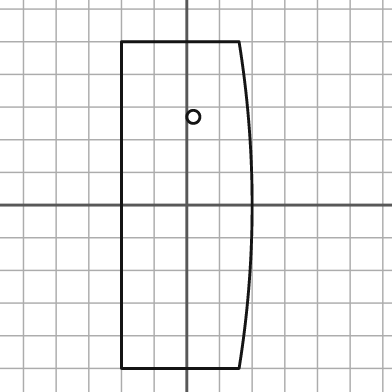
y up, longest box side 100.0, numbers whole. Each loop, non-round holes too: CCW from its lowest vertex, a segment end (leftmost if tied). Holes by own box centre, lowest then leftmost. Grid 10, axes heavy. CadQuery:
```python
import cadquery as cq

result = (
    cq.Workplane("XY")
    .moveTo(-20.0, -50.0)
    .lineTo(16.0, -50.0)
    .threePointArc((20.0, 0.0), (16.0, 50.0))
    .lineTo(-20.0, 50.0)
    .close()
    .moveTo(2.0, 27.0)
    .circle(2.0)
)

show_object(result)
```